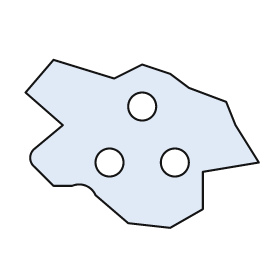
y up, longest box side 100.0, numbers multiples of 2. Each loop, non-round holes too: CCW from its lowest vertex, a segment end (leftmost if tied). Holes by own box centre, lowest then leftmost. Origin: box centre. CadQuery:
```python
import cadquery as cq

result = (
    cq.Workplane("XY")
    .moveTo(12.0, -36.0)
    .lineTo(26.0, -28.0)
    .lineTo(26.0, -12.0)
    .lineTo(50.0, -8.0)
    .lineTo(40.0, 8.0)
    .lineTo(36.0, 18.0)
    .lineTo(20.0, 24.0)
    .lineTo(12.0, 30.0)
    .lineTo(0.0, 34.0)
    .lineTo(-12.0, 28.0)
    .lineTo(-38.0, 36.0)
    .lineTo(-50.0, 22.0)
    .lineTo(-34.0, 8.0)
    .lineTo(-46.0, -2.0)
    .threePointArc((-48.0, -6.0), (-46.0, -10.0))
    .lineTo(-38.0, -18.0)
    .lineTo(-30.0, -18.0)
    .threePointArc((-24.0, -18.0), (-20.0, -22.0))
    .lineTo(-6.0, -34.0)
    .close()
    .moveTo(-14.0, -8.0)
    .circle(6.0)
    .moveTo(14.0, -8.0)
    .circle(6.0)
    .moveTo(0.0, 16.0)
    .circle(6.0)
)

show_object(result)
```